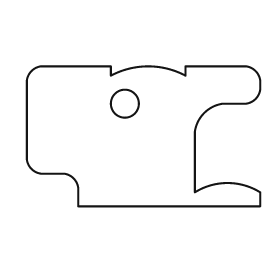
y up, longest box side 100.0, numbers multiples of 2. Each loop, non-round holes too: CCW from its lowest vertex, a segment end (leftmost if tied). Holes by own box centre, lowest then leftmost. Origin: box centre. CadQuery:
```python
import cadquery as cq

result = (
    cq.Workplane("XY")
    .moveTo(-28.0, -30.0)
    .lineTo(50.0, -30.0)
    .lineTo(50.0, -24.0)
    .threePointArc((36.0, -20.0), (22.0, -24.0))
    .lineTo(22.0, 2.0)
    .threePointArc((26.0, 10.0), (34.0, 14.0))
    .lineTo(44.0, 14.0)
    .threePointArc((48.0, 16.0), (50.0, 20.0))
    .lineTo(50.0, 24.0)
    .threePointArc((48.0, 28.0), (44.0, 30.0))
    .lineTo(18.0, 30.0)
    .lineTo(18.0, 26.0)
    .threePointArc((2.0, 30.0), (-14.0, 26.0))
    .lineTo(-14.0, 30.0)
    .lineTo(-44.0, 30.0)
    .threePointArc((-48.0, 28.0), (-50.0, 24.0))
    .lineTo(-50.0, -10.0)
    .threePointArc((-48.0, -14.0), (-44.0, -16.0))
    .lineTo(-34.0, -16.0)
    .threePointArc((-30.0, -18.0), (-28.0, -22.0))
    .close()
    .moveTo(-8.0, 14.0)
    .circle(6.0)
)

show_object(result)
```